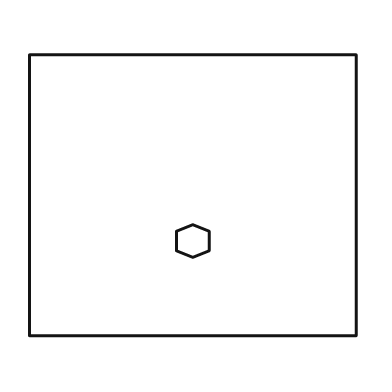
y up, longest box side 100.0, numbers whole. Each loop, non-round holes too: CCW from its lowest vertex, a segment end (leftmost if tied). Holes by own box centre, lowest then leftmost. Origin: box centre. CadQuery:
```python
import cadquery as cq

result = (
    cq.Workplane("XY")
    .moveTo(-50.0, -43.0)
    .lineTo(50.0, -43.0)
    .lineTo(50.0, 43.0)
    .lineTo(-50.0, 43.0)
    .close()
    .moveTo(0.0, -19.0)
    .lineTo(5.0, -17.0)
    .lineTo(5.0, -11.0)
    .lineTo(0.0, -9.0)
    .lineTo(-5.0, -11.0)
    .lineTo(-5.0, -17.0)
    .close()
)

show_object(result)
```